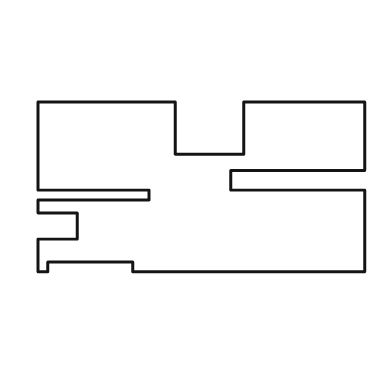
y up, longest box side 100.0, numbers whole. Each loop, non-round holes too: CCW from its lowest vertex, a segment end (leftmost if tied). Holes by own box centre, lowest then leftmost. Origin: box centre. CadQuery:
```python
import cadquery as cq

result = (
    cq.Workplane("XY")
    .moveTo(-50.0, -26.0)
    .lineTo(-47.0, -26.0)
    .lineTo(-47.0, -23.0)
    .lineTo(-21.0, -23.0)
    .lineTo(-21.0, -26.0)
    .lineTo(50.0, -26.0)
    .lineTo(50.0, -1.0)
    .lineTo(9.0, -1.0)
    .lineTo(9.0, 5.0)
    .lineTo(50.0, 5.0)
    .lineTo(50.0, 26.0)
    .lineTo(13.0, 26.0)
    .lineTo(13.0, 10.0)
    .lineTo(-8.0, 10.0)
    .lineTo(-8.0, 26.0)
    .lineTo(-50.0, 26.0)
    .lineTo(-50.0, -1.0)
    .lineTo(-16.0, -1.0)
    .lineTo(-16.0, -4.0)
    .lineTo(-50.0, -4.0)
    .lineTo(-50.0, -8.0)
    .lineTo(-38.0, -8.0)
    .lineTo(-38.0, -16.0)
    .lineTo(-50.0, -16.0)
    .close()
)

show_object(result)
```